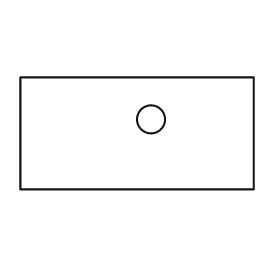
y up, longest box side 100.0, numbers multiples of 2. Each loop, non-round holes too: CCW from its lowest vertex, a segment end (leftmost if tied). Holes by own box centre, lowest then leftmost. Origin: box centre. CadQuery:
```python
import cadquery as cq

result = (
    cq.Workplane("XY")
    .moveTo(-50.0, -24.0)
    .lineTo(50.0, -24.0)
    .lineTo(50.0, 24.0)
    .lineTo(-50.0, 24.0)
    .close()
    .moveTo(6.0, 6.0)
    .circle(6.0)
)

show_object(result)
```